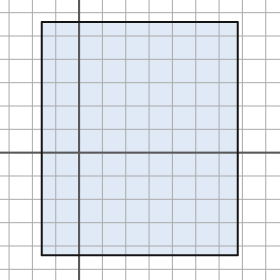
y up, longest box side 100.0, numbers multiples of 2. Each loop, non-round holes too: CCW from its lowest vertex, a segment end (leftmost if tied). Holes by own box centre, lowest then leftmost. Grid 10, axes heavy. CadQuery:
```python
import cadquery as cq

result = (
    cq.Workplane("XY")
    .moveTo(-16.0, -44.0)
    .lineTo(68.0, -44.0)
    .lineTo(68.0, 56.0)
    .lineTo(-16.0, 56.0)
    .close()
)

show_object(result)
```